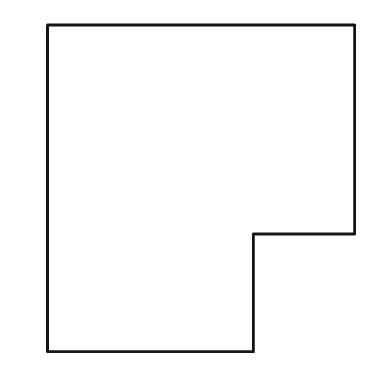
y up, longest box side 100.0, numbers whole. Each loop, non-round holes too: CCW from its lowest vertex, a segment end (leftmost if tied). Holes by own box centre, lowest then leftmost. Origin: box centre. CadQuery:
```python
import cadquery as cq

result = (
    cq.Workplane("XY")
    .moveTo(-47.0, -50.0)
    .lineTo(16.0, -50.0)
    .lineTo(16.0, -14.0)
    .lineTo(47.0, -14.0)
    .lineTo(47.0, 50.0)
    .lineTo(-47.0, 50.0)
    .close()
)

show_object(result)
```